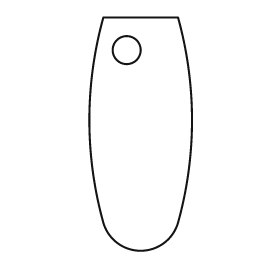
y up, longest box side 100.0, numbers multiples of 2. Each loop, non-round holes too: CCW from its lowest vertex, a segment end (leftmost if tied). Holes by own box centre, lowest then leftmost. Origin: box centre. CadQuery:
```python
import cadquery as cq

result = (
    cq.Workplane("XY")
    .moveTo(-16.0, -38.0)
    .threePointArc((0.0, -50.0), (16.0, -38.0))
    .threePointArc((22.0, 6.0), (16.0, 50.0))
    .lineTo(-16.0, 50.0)
    .threePointArc((-22.0, 6.0), (-16.0, -38.0))
    .close()
    .moveTo(-6.0, 36.0)
    .circle(6.0)
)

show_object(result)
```